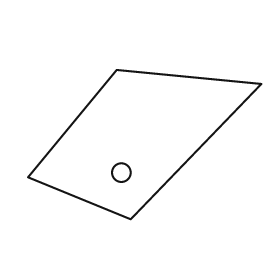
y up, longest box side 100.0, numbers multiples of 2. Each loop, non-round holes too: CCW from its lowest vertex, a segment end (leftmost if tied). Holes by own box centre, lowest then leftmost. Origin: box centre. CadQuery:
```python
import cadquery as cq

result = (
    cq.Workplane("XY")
    .moveTo(-6.0, -32.0)
    .lineTo(50.0, 26.0)
    .lineTo(-12.0, 32.0)
    .lineTo(-50.0, -14.0)
    .close()
    .moveTo(-10.0, -12.0)
    .circle(4.0)
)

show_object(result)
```